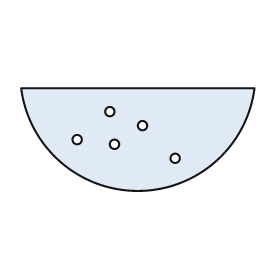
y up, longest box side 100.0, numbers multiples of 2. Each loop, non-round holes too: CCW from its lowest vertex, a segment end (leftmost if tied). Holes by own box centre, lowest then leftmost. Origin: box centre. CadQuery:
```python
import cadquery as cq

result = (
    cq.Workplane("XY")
    .moveTo(-50.0, 22.0)
    .threePointArc((0.0, -22.0), (50.0, 22.0))
    .close()
    .moveTo(16.0, -8.0)
    .circle(2.0)
    .moveTo(-10.0, -2.0)
    .circle(2.0)
    .moveTo(-26.0, 0.0)
    .circle(2.0)
    .moveTo(2.0, 6.0)
    .circle(2.0)
    .moveTo(-12.0, 12.0)
    .circle(2.0)
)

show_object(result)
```